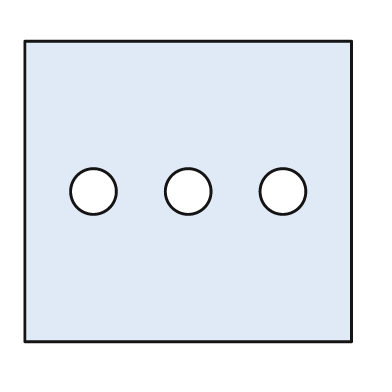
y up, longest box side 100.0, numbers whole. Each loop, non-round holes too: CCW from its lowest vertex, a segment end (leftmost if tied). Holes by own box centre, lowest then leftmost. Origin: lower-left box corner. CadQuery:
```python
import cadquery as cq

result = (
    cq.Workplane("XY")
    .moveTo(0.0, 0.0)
    .lineTo(100.0, 0.0)
    .lineTo(100.0, 92.0)
    .lineTo(0.0, 92.0)
    .close()
    .moveTo(21.0, 46.0)
    .circle(7.0)
    .moveTo(50.0, 46.0)
    .circle(7.0)
    .moveTo(79.0, 46.0)
    .circle(7.0)
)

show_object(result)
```